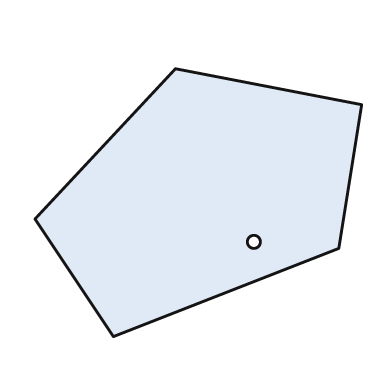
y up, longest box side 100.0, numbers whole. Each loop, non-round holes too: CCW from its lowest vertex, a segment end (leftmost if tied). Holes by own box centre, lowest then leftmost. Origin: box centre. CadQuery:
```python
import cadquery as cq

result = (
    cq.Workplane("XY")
    .moveTo(-26.0, -41.0)
    .lineTo(43.0, -14.0)
    .lineTo(50.0, 30.0)
    .lineTo(-7.0, 41.0)
    .lineTo(-50.0, -5.0)
    .close()
    .moveTo(17.0, -12.0)
    .circle(2.0)
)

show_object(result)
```